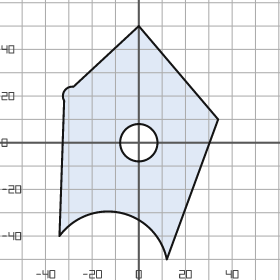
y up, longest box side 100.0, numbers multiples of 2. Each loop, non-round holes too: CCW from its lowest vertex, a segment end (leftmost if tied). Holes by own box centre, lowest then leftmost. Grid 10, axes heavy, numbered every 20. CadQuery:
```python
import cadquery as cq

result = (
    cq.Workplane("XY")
    .moveTo(12.0, -50.0)
    .lineTo(34.0, 10.0)
    .lineTo(0.0, 50.0)
    .lineTo(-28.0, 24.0)
    .threePointArc((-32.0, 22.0), (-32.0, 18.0))
    .lineTo(-34.0, -40.0)
    .threePointArc((-8.0, -30.0), (12.0, -50.0))
    .close()
    .moveTo(0.0, 0.0)
    .circle(8.0)
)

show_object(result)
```